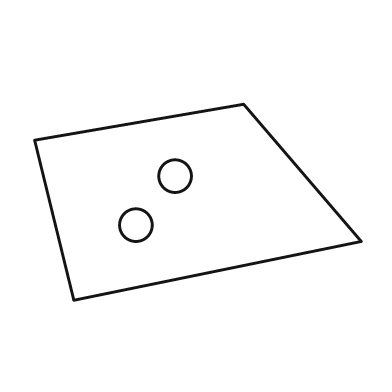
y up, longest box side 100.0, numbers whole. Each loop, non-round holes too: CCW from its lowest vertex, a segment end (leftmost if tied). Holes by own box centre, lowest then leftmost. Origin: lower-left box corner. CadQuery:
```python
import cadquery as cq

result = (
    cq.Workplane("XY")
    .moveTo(12.0, 0.0)
    .lineTo(100.0, 18.0)
    .lineTo(64.0, 60.0)
    .lineTo(0.0, 49.0)
    .close()
    .moveTo(31.0, 23.0)
    .circle(5.0)
    .moveTo(43.0, 38.0)
    .circle(5.0)
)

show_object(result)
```